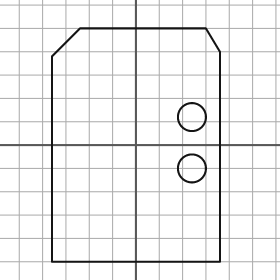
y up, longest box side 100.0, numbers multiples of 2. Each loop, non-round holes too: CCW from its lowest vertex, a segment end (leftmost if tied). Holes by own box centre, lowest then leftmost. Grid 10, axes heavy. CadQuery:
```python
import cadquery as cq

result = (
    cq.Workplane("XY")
    .moveTo(-36.0, -50.0)
    .lineTo(36.0, -50.0)
    .lineTo(36.0, 40.0)
    .lineTo(30.0, 50.0)
    .lineTo(-24.0, 50.0)
    .lineTo(-36.0, 38.0)
    .close()
    .moveTo(24.0, -10.0)
    .circle(6.0)
    .moveTo(24.0, 12.0)
    .circle(6.0)
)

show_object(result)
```